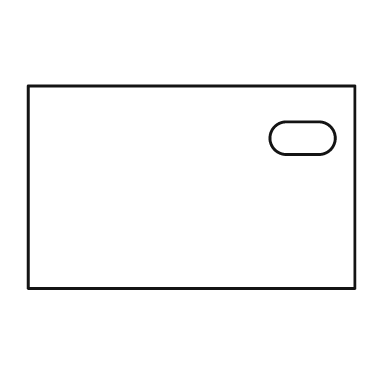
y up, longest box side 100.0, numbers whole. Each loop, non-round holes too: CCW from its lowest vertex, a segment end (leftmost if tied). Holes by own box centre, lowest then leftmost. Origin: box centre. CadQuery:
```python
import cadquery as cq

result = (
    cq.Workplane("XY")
    .moveTo(-50.0, -31.0)
    .lineTo(50.0, -31.0)
    .lineTo(50.0, 31.0)
    .lineTo(-50.0, 31.0)
    .close()
    .moveTo(29.0, 10.0)
    .lineTo(39.0, 10.0)
    .threePointArc((44.0, 15.0), (39.0, 20.0))
    .lineTo(29.0, 20.0)
    .threePointArc((24.0, 15.0), (29.0, 10.0))
    .close()
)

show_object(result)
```